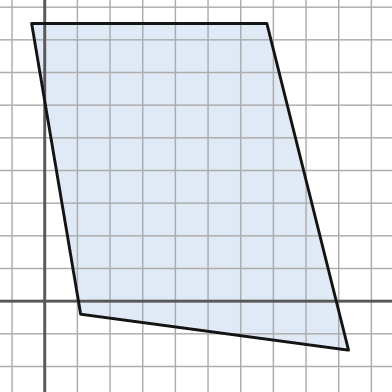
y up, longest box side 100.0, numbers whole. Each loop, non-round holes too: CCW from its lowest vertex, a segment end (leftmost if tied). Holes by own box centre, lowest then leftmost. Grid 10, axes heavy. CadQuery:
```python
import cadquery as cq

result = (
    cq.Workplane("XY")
    .moveTo(93.0, -15.0)
    .lineTo(68.0, 85.0)
    .lineTo(-4.0, 85.0)
    .lineTo(11.0, -4.0)
    .close()
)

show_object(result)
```